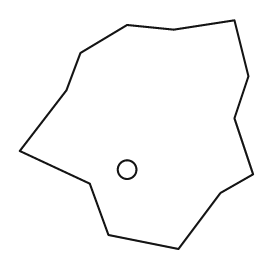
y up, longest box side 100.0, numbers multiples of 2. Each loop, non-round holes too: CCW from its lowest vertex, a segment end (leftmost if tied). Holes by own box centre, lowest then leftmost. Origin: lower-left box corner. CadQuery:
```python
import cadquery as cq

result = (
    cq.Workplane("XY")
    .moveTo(68.0, 0.0)
    .lineTo(86.0, 24.0)
    .lineTo(100.0, 32.0)
    .lineTo(92.0, 56.0)
    .lineTo(98.0, 74.0)
    .lineTo(92.0, 98.0)
    .lineTo(66.0, 94.0)
    .lineTo(46.0, 96.0)
    .lineTo(26.0, 84.0)
    .lineTo(20.0, 68.0)
    .lineTo(0.0, 42.0)
    .lineTo(30.0, 28.0)
    .lineTo(38.0, 6.0)
    .close()
    .moveTo(46.0, 34.0)
    .circle(4.0)
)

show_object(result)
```